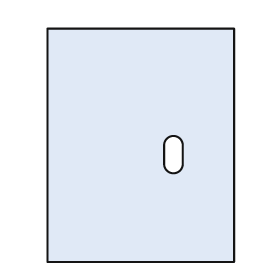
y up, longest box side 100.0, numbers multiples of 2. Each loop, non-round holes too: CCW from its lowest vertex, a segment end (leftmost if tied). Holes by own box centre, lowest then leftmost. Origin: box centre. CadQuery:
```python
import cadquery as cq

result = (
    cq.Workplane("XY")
    .moveTo(-40.0, -50.0)
    .lineTo(40.0, -50.0)
    .lineTo(40.0, 50.0)
    .lineTo(-40.0, 50.0)
    .close()
    .moveTo(10.0, -8.0)
    .threePointArc((14.0, -12.0), (18.0, -8.0))
    .lineTo(18.0, 0.0)
    .threePointArc((14.0, 4.0), (10.0, 0.0))
    .close()
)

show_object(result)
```